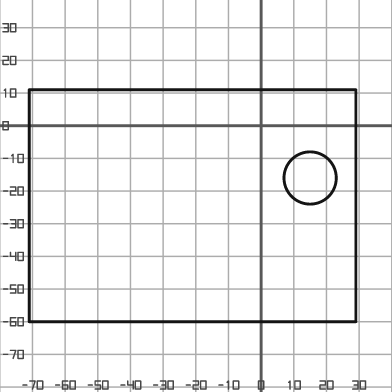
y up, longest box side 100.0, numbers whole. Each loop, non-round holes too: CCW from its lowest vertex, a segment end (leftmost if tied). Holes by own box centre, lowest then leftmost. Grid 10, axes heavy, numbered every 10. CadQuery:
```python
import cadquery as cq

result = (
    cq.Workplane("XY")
    .moveTo(-71.0, -60.0)
    .lineTo(29.0, -60.0)
    .lineTo(29.0, 11.0)
    .lineTo(-71.0, 11.0)
    .close()
    .moveTo(15.0, -16.0)
    .circle(8.0)
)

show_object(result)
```